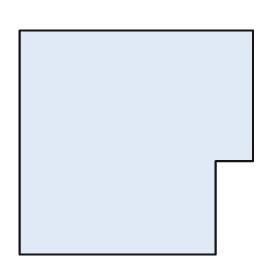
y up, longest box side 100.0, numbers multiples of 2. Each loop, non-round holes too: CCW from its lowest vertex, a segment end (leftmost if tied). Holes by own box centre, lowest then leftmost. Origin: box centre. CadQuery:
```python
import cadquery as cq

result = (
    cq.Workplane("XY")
    .moveTo(-50.0, -48.0)
    .lineTo(34.0, -48.0)
    .lineTo(34.0, -8.0)
    .lineTo(50.0, -8.0)
    .lineTo(50.0, 48.0)
    .lineTo(-50.0, 48.0)
    .close()
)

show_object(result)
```